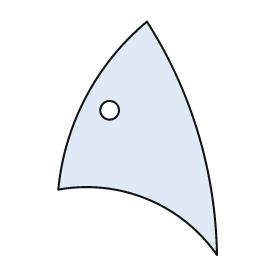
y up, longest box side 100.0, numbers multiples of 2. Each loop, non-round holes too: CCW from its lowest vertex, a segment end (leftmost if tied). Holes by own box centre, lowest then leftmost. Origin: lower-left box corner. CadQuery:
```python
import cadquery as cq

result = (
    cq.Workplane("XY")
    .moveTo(68.0, 0.0)
    .threePointArc((60.0, 52.0), (38.0, 100.0))
    .threePointArc((12.0, 68.0), (0.0, 28.0))
    .threePointArc((38.0, 24.0), (68.0, 0.0))
    .close()
    .moveTo(22.0, 62.0)
    .circle(4.0)
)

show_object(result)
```